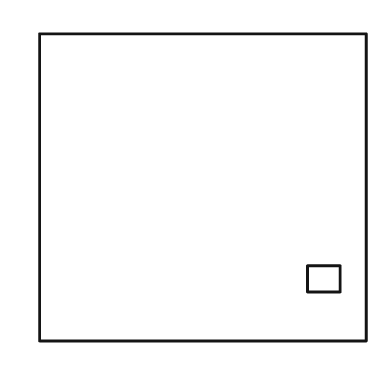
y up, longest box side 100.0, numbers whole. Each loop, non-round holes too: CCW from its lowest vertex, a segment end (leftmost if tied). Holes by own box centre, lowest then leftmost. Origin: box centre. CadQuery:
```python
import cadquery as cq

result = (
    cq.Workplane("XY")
    .moveTo(-50.0, -47.0)
    .lineTo(50.0, -47.0)
    .lineTo(50.0, 47.0)
    .lineTo(-50.0, 47.0)
    .close()
    .moveTo(32.0, -32.0)
    .lineTo(42.0, -32.0)
    .lineTo(42.0, -24.0)
    .lineTo(32.0, -24.0)
    .close()
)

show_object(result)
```